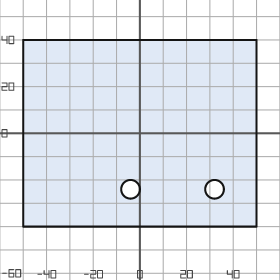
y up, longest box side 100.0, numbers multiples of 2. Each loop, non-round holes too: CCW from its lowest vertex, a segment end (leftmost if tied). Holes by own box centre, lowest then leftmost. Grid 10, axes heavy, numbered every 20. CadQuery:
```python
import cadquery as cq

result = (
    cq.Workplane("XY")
    .moveTo(-50.0, -40.0)
    .lineTo(50.0, -40.0)
    .lineTo(50.0, 40.0)
    .lineTo(-50.0, 40.0)
    .close()
    .moveTo(-4.0, -24.0)
    .circle(4.0)
    .moveTo(32.0, -24.0)
    .circle(4.0)
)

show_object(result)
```